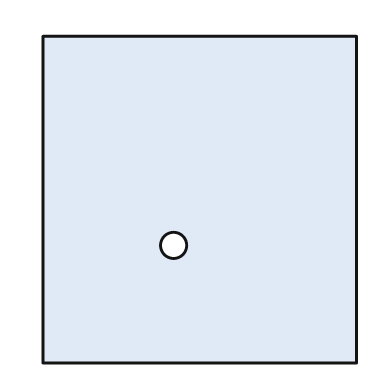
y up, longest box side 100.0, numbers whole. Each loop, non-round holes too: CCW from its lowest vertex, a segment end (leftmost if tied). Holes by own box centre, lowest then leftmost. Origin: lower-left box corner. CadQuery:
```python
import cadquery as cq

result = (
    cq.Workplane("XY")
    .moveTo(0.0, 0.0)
    .lineTo(96.0, 0.0)
    .lineTo(96.0, 100.0)
    .lineTo(0.0, 100.0)
    .close()
    .moveTo(40.0, 36.0)
    .circle(4.0)
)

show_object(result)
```